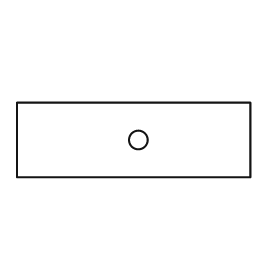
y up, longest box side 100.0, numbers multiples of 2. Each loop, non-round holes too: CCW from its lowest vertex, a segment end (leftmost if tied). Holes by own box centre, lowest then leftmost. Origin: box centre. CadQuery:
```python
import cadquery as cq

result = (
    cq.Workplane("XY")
    .moveTo(-50.0, -16.0)
    .lineTo(50.0, -16.0)
    .lineTo(50.0, 16.0)
    .lineTo(-50.0, 16.0)
    .close()
    .moveTo(2.0, 0.0)
    .circle(4.0)
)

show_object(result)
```